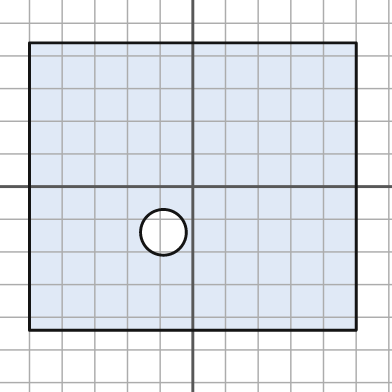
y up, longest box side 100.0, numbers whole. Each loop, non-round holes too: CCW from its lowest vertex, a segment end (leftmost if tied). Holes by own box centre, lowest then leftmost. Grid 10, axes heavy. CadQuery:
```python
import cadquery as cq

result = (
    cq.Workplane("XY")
    .moveTo(-50.0, -44.0)
    .lineTo(50.0, -44.0)
    .lineTo(50.0, 44.0)
    .lineTo(-50.0, 44.0)
    .close()
    .moveTo(-9.0, -14.0)
    .circle(7.0)
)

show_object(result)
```